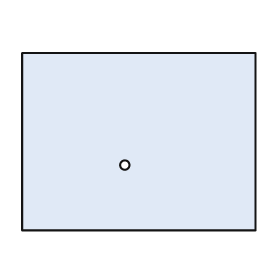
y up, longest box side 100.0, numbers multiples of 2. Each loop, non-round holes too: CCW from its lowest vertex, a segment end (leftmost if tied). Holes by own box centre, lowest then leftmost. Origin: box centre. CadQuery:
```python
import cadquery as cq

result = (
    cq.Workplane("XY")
    .moveTo(-50.0, -38.0)
    .lineTo(50.0, -38.0)
    .lineTo(50.0, 38.0)
    .lineTo(-50.0, 38.0)
    .close()
    .moveTo(-6.0, -10.0)
    .circle(2.0)
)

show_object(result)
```